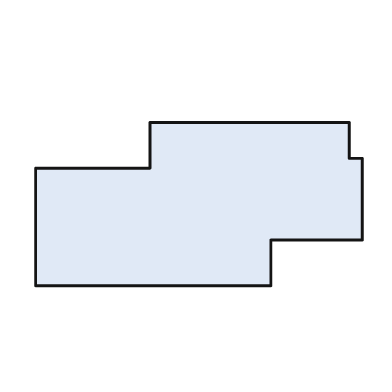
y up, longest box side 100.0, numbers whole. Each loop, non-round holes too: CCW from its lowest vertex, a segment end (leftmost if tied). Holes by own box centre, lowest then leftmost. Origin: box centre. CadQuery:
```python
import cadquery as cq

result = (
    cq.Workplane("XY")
    .moveTo(-50.0, -25.0)
    .lineTo(22.0, -25.0)
    .lineTo(22.0, -11.0)
    .lineTo(50.0, -11.0)
    .lineTo(50.0, 14.0)
    .lineTo(46.0, 14.0)
    .lineTo(46.0, 25.0)
    .lineTo(-15.0, 25.0)
    .lineTo(-15.0, 11.0)
    .lineTo(-50.0, 11.0)
    .close()
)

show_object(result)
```